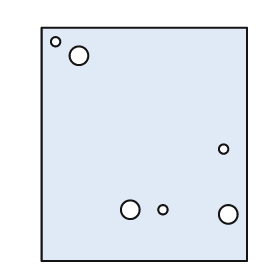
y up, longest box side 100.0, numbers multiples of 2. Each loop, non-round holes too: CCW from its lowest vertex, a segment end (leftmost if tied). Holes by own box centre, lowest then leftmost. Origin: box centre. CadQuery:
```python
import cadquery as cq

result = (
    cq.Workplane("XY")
    .moveTo(-44.0, -50.0)
    .lineTo(44.0, -50.0)
    .lineTo(44.0, 50.0)
    .lineTo(-44.0, 50.0)
    .close()
    .moveTo(36.0, -30.0)
    .circle(4.0)
    .moveTo(-6.0, -28.0)
    .circle(4.0)
    .moveTo(8.0, -28.0)
    .circle(2.0)
    .moveTo(34.0, -2.0)
    .circle(2.0)
    .moveTo(-28.0, 38.0)
    .circle(4.0)
    .moveTo(-38.0, 44.0)
    .circle(2.0)
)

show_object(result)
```